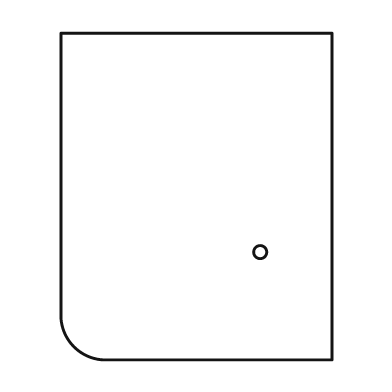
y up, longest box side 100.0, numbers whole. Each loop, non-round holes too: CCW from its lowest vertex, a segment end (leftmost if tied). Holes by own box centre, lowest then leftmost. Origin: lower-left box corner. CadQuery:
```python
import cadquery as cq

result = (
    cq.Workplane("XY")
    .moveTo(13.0, 0.0)
    .lineTo(83.0, 0.0)
    .lineTo(83.0, 100.0)
    .lineTo(0.0, 100.0)
    .lineTo(0.0, 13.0)
    .threePointArc((4.0, 4.0), (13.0, 0.0))
    .close()
    .moveTo(61.0, 33.0)
    .circle(2.0)
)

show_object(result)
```